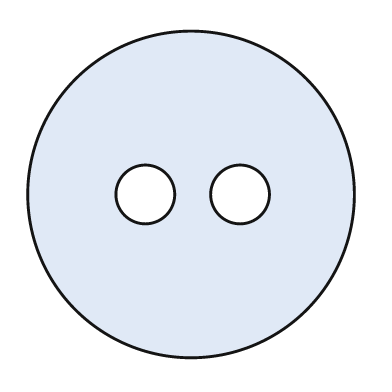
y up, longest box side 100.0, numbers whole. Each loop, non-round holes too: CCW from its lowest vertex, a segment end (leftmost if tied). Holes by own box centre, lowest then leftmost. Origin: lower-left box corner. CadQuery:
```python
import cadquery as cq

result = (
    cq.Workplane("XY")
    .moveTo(50.0, 50.0)
    .circle(50.0)
    .moveTo(36.0, 50.0)
    .circle(9.0)
    .moveTo(65.0, 50.0)
    .circle(9.0)
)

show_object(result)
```